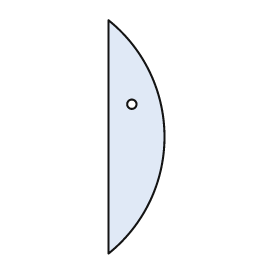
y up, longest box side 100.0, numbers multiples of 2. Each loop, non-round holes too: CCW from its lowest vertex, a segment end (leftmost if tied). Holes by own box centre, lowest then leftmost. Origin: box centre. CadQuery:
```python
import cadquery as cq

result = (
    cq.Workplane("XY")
    .moveTo(-12.0, -50.0)
    .threePointArc((12.0, 0.0), (-12.0, 50.0))
    .close()
    .moveTo(-2.0, 14.0)
    .circle(2.0)
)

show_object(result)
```